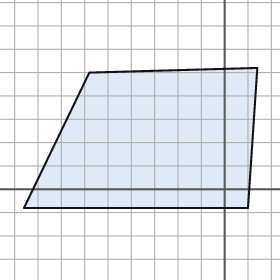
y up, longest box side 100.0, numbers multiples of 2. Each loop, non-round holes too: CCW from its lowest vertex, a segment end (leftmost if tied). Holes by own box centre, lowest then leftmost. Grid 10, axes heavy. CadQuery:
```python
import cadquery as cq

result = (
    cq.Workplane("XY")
    .moveTo(-86.0, -8.0)
    .lineTo(10.0, -8.0)
    .lineTo(14.0, 52.0)
    .lineTo(-58.0, 50.0)
    .close()
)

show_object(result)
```